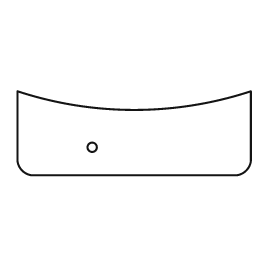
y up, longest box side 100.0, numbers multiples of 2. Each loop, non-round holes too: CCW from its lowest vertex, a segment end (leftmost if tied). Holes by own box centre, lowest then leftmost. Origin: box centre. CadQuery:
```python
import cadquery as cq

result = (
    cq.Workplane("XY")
    .moveTo(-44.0, -18.0)
    .lineTo(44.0, -18.0)
    .threePointArc((48.0, -16.0), (50.0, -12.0))
    .lineTo(50.0, 18.0)
    .threePointArc((0.0, 10.0), (-50.0, 18.0))
    .lineTo(-50.0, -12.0)
    .threePointArc((-48.0, -16.0), (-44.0, -18.0))
    .close()
    .moveTo(-18.0, -6.0)
    .circle(2.0)
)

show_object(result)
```